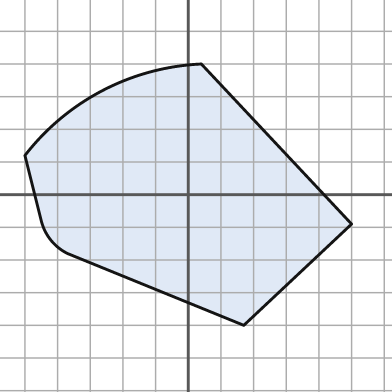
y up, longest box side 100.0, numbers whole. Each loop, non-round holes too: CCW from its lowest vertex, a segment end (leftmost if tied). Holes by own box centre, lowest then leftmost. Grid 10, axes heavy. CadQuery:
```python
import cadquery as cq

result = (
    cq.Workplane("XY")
    .moveTo(17.0, -40.0)
    .lineTo(50.0, -9.0)
    .lineTo(4.0, 40.0)
    .threePointArc((-26.0, 32.0), (-50.0, 12.0))
    .lineTo(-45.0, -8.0)
    .threePointArc((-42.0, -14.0), (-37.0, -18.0))
    .close()
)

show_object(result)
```